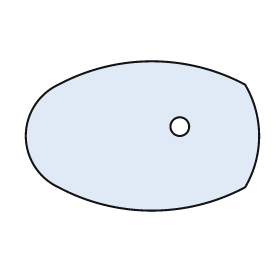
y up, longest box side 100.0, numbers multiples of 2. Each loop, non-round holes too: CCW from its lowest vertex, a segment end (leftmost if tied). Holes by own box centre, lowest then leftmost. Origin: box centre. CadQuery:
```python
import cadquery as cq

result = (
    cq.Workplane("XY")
    .moveTo(-36.0, -22.0)
    .threePointArc((4.0, -32.0), (44.0, -22.0))
    .threePointArc((50.0, 0.0), (44.0, 22.0))
    .threePointArc((4.0, 32.0), (-36.0, 22.0))
    .threePointArc((-50.0, 0.0), (-36.0, -22.0))
    .close()
    .moveTo(16.0, 4.0)
    .circle(4.0)
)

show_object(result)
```